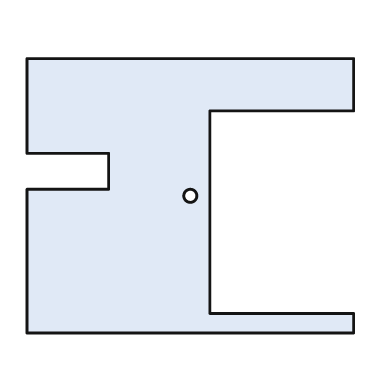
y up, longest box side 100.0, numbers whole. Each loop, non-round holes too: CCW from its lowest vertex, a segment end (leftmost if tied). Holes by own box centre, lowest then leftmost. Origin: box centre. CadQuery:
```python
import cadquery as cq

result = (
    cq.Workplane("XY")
    .moveTo(-50.0, -42.0)
    .lineTo(50.0, -42.0)
    .lineTo(50.0, -36.0)
    .lineTo(6.0, -36.0)
    .lineTo(6.0, 26.0)
    .lineTo(50.0, 26.0)
    .lineTo(50.0, 42.0)
    .lineTo(-50.0, 42.0)
    .lineTo(-50.0, 13.0)
    .lineTo(-25.0, 13.0)
    .lineTo(-25.0, 2.0)
    .lineTo(-50.0, 2.0)
    .close()
    .moveTo(0.0, 0.0)
    .circle(2.0)
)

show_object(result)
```